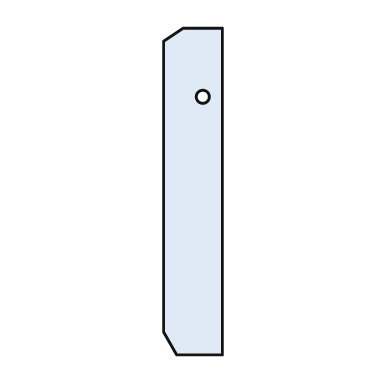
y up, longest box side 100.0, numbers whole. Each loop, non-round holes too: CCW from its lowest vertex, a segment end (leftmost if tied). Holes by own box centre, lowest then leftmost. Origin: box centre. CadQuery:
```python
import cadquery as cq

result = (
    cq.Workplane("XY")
    .moveTo(-5.0, -50.0)
    .lineTo(9.0, -50.0)
    .lineTo(9.0, 50.0)
    .lineTo(-3.0, 50.0)
    .lineTo(-9.0, 46.0)
    .lineTo(-9.0, -43.0)
    .close()
    .moveTo(3.0, 29.0)
    .circle(2.0)
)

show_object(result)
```